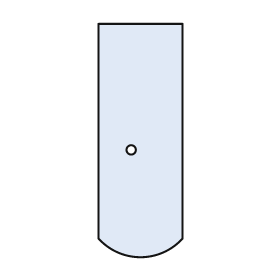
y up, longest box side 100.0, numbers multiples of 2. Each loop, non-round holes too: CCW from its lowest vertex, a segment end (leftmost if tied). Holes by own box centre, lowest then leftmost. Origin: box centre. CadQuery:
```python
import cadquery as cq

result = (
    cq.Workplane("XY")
    .moveTo(-18.0, -42.0)
    .threePointArc((0.0, -50.0), (18.0, -42.0))
    .lineTo(18.0, 50.0)
    .lineTo(-18.0, 50.0)
    .close()
    .moveTo(-4.0, -4.0)
    .circle(2.0)
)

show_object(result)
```